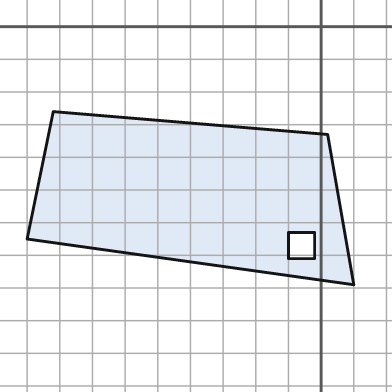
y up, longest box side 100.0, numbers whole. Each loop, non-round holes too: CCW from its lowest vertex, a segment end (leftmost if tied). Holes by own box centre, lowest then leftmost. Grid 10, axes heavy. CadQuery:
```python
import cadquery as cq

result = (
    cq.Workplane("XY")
    .moveTo(10.0, -79.0)
    .lineTo(2.0, -33.0)
    .lineTo(-82.0, -26.0)
    .lineTo(-90.0, -65.0)
    .close()
    .moveTo(-10.0, -71.0)
    .lineTo(-2.0, -71.0)
    .lineTo(-2.0, -63.0)
    .lineTo(-10.0, -63.0)
    .close()
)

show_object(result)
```